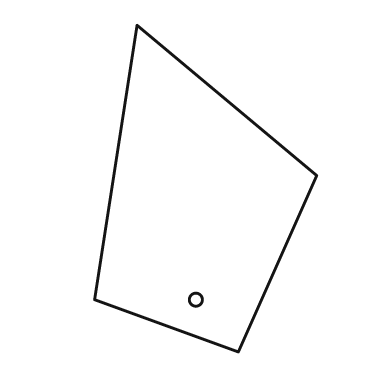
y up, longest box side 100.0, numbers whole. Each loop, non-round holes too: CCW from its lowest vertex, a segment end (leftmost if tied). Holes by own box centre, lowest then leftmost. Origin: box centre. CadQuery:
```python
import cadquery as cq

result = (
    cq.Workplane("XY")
    .moveTo(10.0, -50.0)
    .lineTo(34.0, 4.0)
    .lineTo(-21.0, 50.0)
    .lineTo(-34.0, -34.0)
    .close()
    .moveTo(-3.0, -34.0)
    .circle(2.0)
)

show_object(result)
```